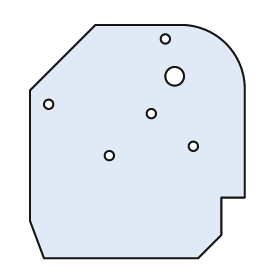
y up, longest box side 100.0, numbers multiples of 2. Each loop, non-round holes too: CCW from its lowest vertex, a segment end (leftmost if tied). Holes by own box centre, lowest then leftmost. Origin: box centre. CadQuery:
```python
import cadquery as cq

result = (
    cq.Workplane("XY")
    .moveTo(-40.0, -50.0)
    .lineTo(26.0, -50.0)
    .lineTo(36.0, -40.0)
    .lineTo(36.0, -24.0)
    .lineTo(46.0, -24.0)
    .lineTo(46.0, 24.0)
    .threePointArc((38.0, 42.0), (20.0, 50.0))
    .lineTo(-18.0, 50.0)
    .lineTo(-46.0, 22.0)
    .lineTo(-46.0, -34.0)
    .close()
    .moveTo(-12.0, -6.0)
    .circle(2.0)
    .moveTo(24.0, -2.0)
    .circle(2.0)
    .moveTo(6.0, 12.0)
    .circle(2.0)
    .moveTo(-38.0, 16.0)
    .circle(2.0)
    .moveTo(16.0, 28.0)
    .circle(4.0)
    .moveTo(12.0, 44.0)
    .circle(2.0)
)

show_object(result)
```